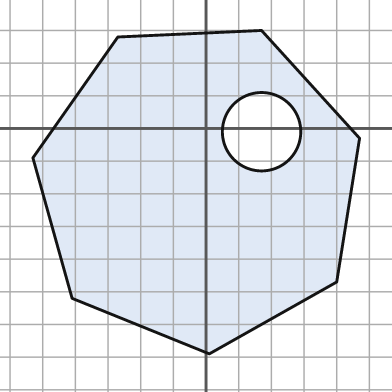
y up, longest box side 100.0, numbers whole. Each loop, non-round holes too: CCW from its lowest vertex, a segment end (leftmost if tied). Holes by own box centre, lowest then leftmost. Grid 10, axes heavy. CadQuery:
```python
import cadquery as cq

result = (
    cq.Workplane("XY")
    .moveTo(1.0, -69.0)
    .lineTo(40.0, -47.0)
    .lineTo(47.0, -3.0)
    .lineTo(17.0, 30.0)
    .lineTo(-27.0, 28.0)
    .lineTo(-53.0, -9.0)
    .lineTo(-41.0, -52.0)
    .close()
    .moveTo(17.0, -1.0)
    .circle(12.0)
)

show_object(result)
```